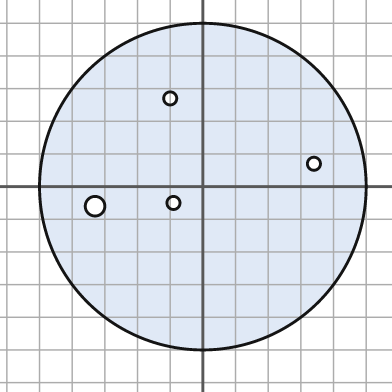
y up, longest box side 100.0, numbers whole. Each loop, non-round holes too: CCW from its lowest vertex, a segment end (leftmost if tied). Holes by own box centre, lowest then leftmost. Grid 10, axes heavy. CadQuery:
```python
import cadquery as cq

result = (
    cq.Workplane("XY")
    .moveTo(0.0, 0.0)
    .circle(50.0)
    .moveTo(-33.0, -6.0)
    .circle(3.0)
    .moveTo(-9.0, -5.0)
    .circle(2.0)
    .moveTo(34.0, 7.0)
    .circle(2.0)
    .moveTo(-10.0, 27.0)
    .circle(2.0)
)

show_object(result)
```